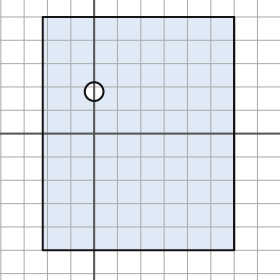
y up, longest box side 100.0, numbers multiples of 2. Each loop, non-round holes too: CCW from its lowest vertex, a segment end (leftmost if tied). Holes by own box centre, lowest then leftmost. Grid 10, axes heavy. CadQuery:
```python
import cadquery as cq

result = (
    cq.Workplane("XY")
    .moveTo(-22.0, -50.0)
    .lineTo(60.0, -50.0)
    .lineTo(60.0, 50.0)
    .lineTo(-22.0, 50.0)
    .close()
    .moveTo(0.0, 18.0)
    .circle(4.0)
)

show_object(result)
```